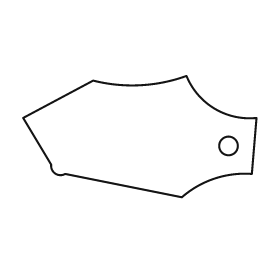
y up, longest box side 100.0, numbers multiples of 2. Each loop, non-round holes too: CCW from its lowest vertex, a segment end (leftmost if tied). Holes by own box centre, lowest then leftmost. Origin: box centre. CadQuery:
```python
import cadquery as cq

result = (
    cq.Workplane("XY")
    .moveTo(18.0, -26.0)
    .threePointArc((32.0, -18.0), (48.0, -16.0))
    .lineTo(50.0, 8.0)
    .threePointArc((32.0, 12.0), (20.0, 26.0))
    .threePointArc((0.0, 22.0), (-20.0, 24.0))
    .lineTo(-50.0, 8.0)
    .lineTo(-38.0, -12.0)
    .threePointArc((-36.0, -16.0), (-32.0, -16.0))
    .close()
    .moveTo(38.0, -4.0)
    .circle(4.0)
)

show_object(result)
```